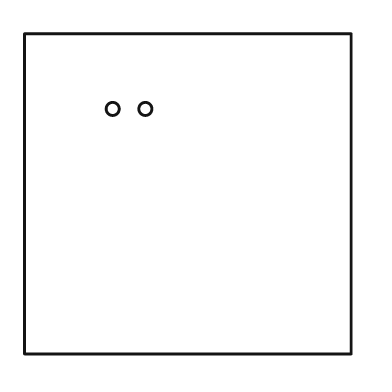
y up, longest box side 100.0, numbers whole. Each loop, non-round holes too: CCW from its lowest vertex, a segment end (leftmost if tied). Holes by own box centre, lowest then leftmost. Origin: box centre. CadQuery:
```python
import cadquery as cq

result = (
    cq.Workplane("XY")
    .moveTo(-50.0, -49.0)
    .lineTo(50.0, -49.0)
    .lineTo(50.0, 49.0)
    .lineTo(-50.0, 49.0)
    .close()
    .moveTo(-23.0, 26.0)
    .circle(2.0)
    .moveTo(-13.0, 26.0)
    .circle(2.0)
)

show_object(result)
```